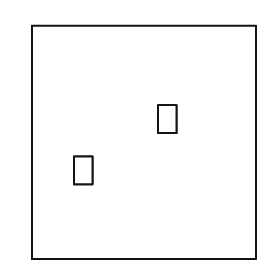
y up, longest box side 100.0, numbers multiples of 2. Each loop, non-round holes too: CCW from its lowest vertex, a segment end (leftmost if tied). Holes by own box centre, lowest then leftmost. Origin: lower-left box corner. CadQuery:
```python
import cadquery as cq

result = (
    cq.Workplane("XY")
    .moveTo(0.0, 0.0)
    .lineTo(96.0, 0.0)
    .lineTo(96.0, 100.0)
    .lineTo(0.0, 100.0)
    .close()
    .moveTo(18.0, 32.0)
    .lineTo(26.0, 32.0)
    .lineTo(26.0, 44.0)
    .lineTo(18.0, 44.0)
    .close()
    .moveTo(54.0, 54.0)
    .lineTo(62.0, 54.0)
    .lineTo(62.0, 66.0)
    .lineTo(54.0, 66.0)
    .close()
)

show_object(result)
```